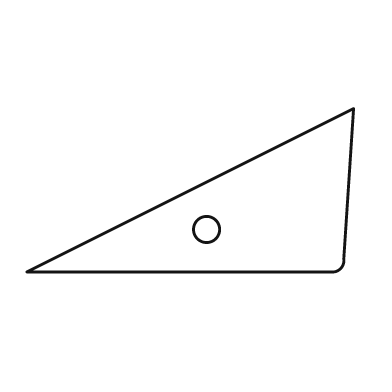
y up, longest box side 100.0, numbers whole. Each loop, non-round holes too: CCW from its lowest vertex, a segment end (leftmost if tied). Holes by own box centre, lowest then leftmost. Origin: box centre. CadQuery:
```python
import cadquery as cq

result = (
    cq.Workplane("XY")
    .moveTo(-50.0, -25.0)
    .lineTo(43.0, -25.0)
    .threePointArc((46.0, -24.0), (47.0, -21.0))
    .lineTo(50.0, 25.0)
    .close()
    .moveTo(5.0, -12.0)
    .circle(4.0)
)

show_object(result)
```